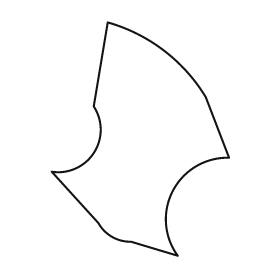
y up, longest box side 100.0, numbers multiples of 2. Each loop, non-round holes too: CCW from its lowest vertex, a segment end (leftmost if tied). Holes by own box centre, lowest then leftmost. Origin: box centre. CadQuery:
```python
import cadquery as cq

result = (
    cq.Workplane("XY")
    .moveTo(16.0, -50.0)
    .threePointArc((14.0, -22.0), (38.0, -8.0))
    .lineTo(28.0, 18.0)
    .threePointArc((10.0, 38.0), (-14.0, 50.0))
    .lineTo(-20.0, 14.0)
    .threePointArc((-20.0, -6.0), (-38.0, -14.0))
    .lineTo(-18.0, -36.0)
    .threePointArc((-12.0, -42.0), (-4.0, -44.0))
    .close()
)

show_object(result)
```